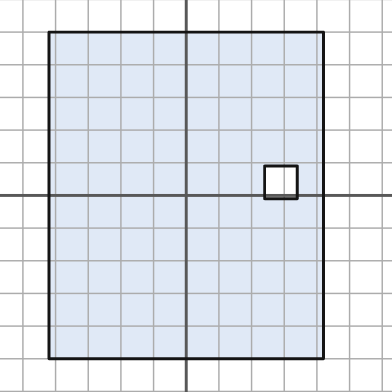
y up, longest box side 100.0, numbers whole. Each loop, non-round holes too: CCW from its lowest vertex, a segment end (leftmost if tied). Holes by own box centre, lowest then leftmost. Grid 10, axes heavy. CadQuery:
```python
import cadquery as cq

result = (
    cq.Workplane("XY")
    .moveTo(-42.0, -50.0)
    .lineTo(42.0, -50.0)
    .lineTo(42.0, 50.0)
    .lineTo(-42.0, 50.0)
    .close()
    .moveTo(24.0, -1.0)
    .lineTo(34.0, -1.0)
    .lineTo(34.0, 9.0)
    .lineTo(24.0, 9.0)
    .close()
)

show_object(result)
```